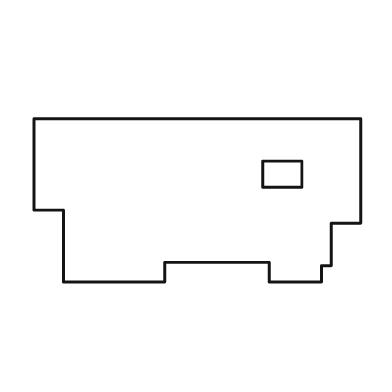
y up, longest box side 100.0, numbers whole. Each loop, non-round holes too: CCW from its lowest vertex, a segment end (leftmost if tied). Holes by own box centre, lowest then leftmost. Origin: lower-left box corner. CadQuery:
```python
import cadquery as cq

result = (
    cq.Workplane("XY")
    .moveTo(9.0, 0.0)
    .lineTo(40.0, 0.0)
    .lineTo(40.0, 6.0)
    .lineTo(72.0, 6.0)
    .lineTo(72.0, 0.0)
    .lineTo(88.0, 0.0)
    .lineTo(88.0, 5.0)
    .lineTo(91.0, 5.0)
    .lineTo(91.0, 18.0)
    .lineTo(100.0, 18.0)
    .lineTo(100.0, 50.0)
    .lineTo(0.0, 50.0)
    .lineTo(0.0, 22.0)
    .lineTo(9.0, 22.0)
    .close()
    .moveTo(70.0, 29.0)
    .lineTo(82.0, 29.0)
    .lineTo(82.0, 37.0)
    .lineTo(70.0, 37.0)
    .close()
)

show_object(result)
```